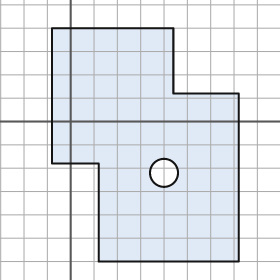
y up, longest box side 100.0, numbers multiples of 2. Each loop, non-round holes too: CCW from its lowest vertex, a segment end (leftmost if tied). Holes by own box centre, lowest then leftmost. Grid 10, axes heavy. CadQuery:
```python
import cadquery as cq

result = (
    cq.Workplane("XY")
    .moveTo(12.0, -60.0)
    .lineTo(72.0, -60.0)
    .lineTo(72.0, 12.0)
    .lineTo(44.0, 12.0)
    .lineTo(44.0, 40.0)
    .lineTo(-8.0, 40.0)
    .lineTo(-8.0, -18.0)
    .lineTo(12.0, -18.0)
    .close()
    .moveTo(40.0, -22.0)
    .circle(6.0)
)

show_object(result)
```